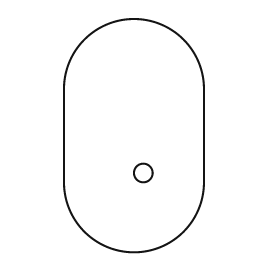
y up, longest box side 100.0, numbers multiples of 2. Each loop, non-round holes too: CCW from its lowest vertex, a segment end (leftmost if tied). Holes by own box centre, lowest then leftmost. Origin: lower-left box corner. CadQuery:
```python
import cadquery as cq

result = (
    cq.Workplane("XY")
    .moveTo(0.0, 30.0)
    .threePointArc((30.0, 0.0), (60.0, 30.0))
    .lineTo(60.0, 70.0)
    .threePointArc((30.0, 100.0), (0.0, 70.0))
    .close()
    .moveTo(34.0, 34.0)
    .circle(4.0)
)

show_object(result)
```